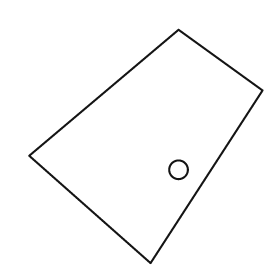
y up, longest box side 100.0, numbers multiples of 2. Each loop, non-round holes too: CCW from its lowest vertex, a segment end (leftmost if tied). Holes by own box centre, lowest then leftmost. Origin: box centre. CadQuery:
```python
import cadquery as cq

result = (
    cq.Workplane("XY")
    .moveTo(2.0, -50.0)
    .lineTo(50.0, 24.0)
    .lineTo(14.0, 50.0)
    .lineTo(-50.0, -4.0)
    .close()
    .moveTo(14.0, -10.0)
    .circle(4.0)
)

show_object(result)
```